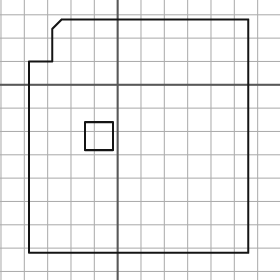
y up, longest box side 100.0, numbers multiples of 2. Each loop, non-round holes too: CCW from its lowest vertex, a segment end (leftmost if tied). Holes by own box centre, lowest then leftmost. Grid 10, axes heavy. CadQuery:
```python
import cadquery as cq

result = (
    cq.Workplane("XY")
    .moveTo(-38.0, -72.0)
    .lineTo(56.0, -72.0)
    .lineTo(56.0, 28.0)
    .lineTo(-24.0, 28.0)
    .lineTo(-28.0, 24.0)
    .lineTo(-28.0, 10.0)
    .lineTo(-38.0, 10.0)
    .close()
    .moveTo(-14.0, -28.0)
    .lineTo(-2.0, -28.0)
    .lineTo(-2.0, -16.0)
    .lineTo(-14.0, -16.0)
    .close()
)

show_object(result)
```